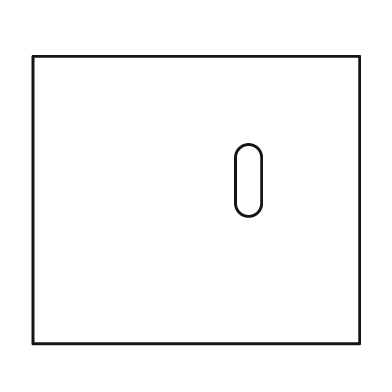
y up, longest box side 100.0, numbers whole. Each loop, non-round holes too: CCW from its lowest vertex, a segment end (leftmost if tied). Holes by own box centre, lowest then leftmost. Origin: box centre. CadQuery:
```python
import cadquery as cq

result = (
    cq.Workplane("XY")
    .moveTo(-50.0, -44.0)
    .lineTo(50.0, -44.0)
    .lineTo(50.0, 44.0)
    .lineTo(-50.0, 44.0)
    .close()
    .moveTo(12.0, -1.0)
    .threePointArc((16.0, -5.0), (20.0, -1.0))
    .lineTo(20.0, 13.0)
    .threePointArc((16.0, 17.0), (12.0, 13.0))
    .close()
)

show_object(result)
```